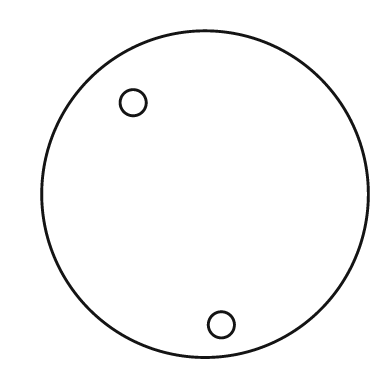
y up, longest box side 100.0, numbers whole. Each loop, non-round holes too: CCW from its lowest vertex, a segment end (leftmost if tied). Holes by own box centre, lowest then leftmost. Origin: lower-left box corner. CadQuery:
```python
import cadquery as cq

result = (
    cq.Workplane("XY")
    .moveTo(50.0, 50.0)
    .circle(50.0)
    .moveTo(55.0, 10.0)
    .circle(4.0)
    .moveTo(28.0, 78.0)
    .circle(4.0)
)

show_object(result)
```